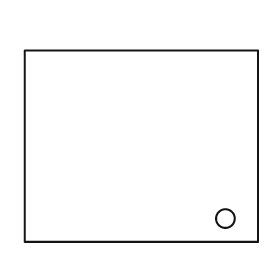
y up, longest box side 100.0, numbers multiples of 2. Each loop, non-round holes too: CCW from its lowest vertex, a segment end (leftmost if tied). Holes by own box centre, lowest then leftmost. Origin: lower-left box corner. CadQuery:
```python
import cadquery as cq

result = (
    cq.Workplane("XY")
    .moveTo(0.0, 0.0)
    .lineTo(100.0, 0.0)
    .lineTo(100.0, 82.0)
    .lineTo(0.0, 82.0)
    .close()
    .moveTo(86.0, 10.0)
    .circle(4.0)
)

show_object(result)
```